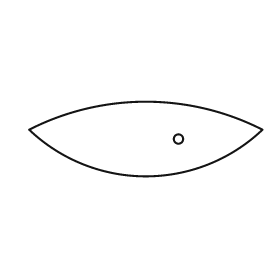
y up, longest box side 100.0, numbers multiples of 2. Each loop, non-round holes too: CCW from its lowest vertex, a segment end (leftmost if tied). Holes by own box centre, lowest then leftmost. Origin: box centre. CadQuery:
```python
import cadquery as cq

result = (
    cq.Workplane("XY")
    .moveTo(-50.0, 4.0)
    .threePointArc((0.0, -16.0), (50.0, 4.0))
    .threePointArc((0.0, 16.0), (-50.0, 4.0))
    .close()
    .moveTo(14.0, 0.0)
    .circle(2.0)
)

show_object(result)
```